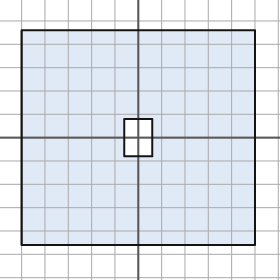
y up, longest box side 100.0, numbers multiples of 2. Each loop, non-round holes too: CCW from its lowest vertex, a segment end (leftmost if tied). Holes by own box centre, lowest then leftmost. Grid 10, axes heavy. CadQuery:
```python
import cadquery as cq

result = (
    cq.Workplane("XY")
    .moveTo(-50.0, -46.0)
    .lineTo(50.0, -46.0)
    .lineTo(50.0, 46.0)
    .lineTo(-50.0, 46.0)
    .close()
    .moveTo(-6.0, -8.0)
    .lineTo(6.0, -8.0)
    .lineTo(6.0, 8.0)
    .lineTo(-6.0, 8.0)
    .close()
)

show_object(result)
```